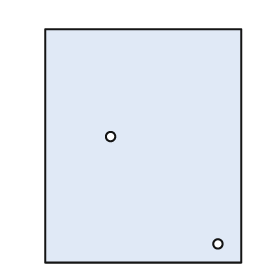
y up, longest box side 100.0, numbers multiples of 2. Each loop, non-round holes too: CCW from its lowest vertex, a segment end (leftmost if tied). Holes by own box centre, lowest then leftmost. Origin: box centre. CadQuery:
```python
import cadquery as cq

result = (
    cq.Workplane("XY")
    .moveTo(-42.0, -50.0)
    .lineTo(42.0, -50.0)
    .lineTo(42.0, 50.0)
    .lineTo(-42.0, 50.0)
    .close()
    .moveTo(32.0, -42.0)
    .circle(2.0)
    .moveTo(-14.0, 4.0)
    .circle(2.0)
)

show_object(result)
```